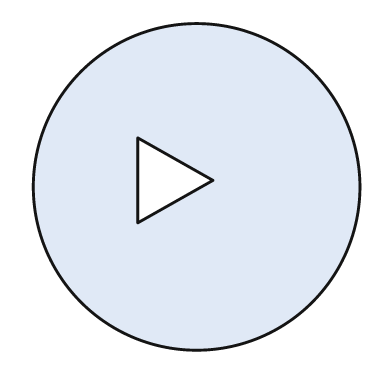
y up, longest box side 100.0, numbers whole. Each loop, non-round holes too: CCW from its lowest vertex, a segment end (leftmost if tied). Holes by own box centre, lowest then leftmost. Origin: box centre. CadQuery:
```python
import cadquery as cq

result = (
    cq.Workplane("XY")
    .moveTo(0.0, 0.0)
    .circle(50.0)
    .moveTo(-18.0, -11.0)
    .lineTo(5.0, 2.0)
    .lineTo(-18.0, 15.0)
    .close()
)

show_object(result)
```